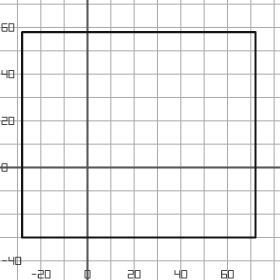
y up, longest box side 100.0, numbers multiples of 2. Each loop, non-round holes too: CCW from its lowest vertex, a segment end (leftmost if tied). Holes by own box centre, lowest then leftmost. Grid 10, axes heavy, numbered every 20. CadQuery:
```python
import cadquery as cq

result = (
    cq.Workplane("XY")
    .moveTo(-28.0, -30.0)
    .lineTo(72.0, -30.0)
    .lineTo(72.0, 58.0)
    .lineTo(-28.0, 58.0)
    .close()
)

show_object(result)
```